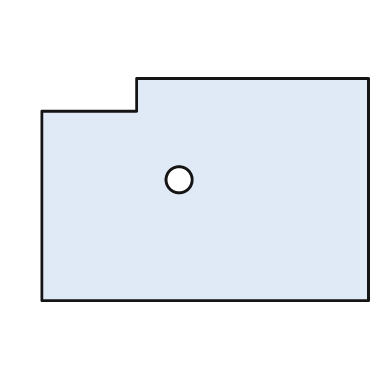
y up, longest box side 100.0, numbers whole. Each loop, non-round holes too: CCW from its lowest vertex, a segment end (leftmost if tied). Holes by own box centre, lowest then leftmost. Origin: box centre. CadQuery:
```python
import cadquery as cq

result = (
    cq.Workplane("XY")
    .moveTo(-50.0, -34.0)
    .lineTo(50.0, -34.0)
    .lineTo(50.0, 34.0)
    .lineTo(-21.0, 34.0)
    .lineTo(-21.0, 24.0)
    .lineTo(-50.0, 24.0)
    .close()
    .moveTo(-8.0, 3.0)
    .circle(4.0)
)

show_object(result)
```